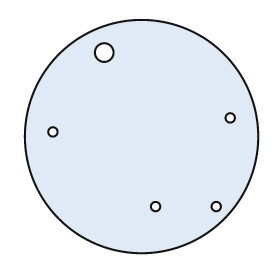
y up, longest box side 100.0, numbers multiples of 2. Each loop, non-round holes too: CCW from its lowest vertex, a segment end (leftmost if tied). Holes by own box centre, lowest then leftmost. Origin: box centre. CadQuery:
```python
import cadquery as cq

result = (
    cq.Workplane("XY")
    .moveTo(0.0, 0.0)
    .circle(50.0)
    .moveTo(6.0, -30.0)
    .circle(2.0)
    .moveTo(32.0, -30.0)
    .circle(2.0)
    .moveTo(-38.0, 2.0)
    .circle(2.0)
    .moveTo(38.0, 8.0)
    .circle(2.0)
    .moveTo(-16.0, 36.0)
    .circle(4.0)
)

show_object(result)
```